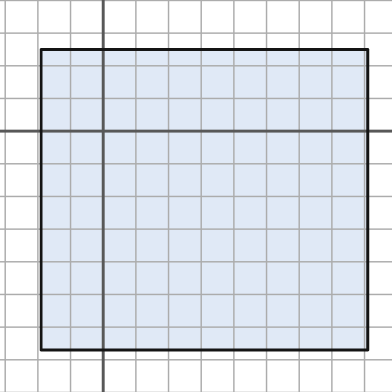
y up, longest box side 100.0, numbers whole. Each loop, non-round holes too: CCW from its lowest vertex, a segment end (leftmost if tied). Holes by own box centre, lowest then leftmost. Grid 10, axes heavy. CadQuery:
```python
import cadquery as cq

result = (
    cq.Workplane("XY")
    .moveTo(-19.0, -67.0)
    .lineTo(81.0, -67.0)
    .lineTo(81.0, 25.0)
    .lineTo(-19.0, 25.0)
    .close()
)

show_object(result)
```